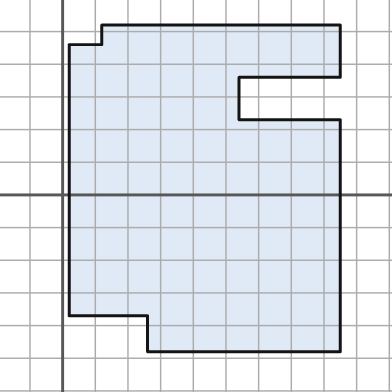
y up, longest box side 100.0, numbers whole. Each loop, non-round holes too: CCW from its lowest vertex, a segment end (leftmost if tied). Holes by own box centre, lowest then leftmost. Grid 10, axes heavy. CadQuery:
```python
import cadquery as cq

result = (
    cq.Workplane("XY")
    .moveTo(26.0, -48.0)
    .lineTo(85.0, -48.0)
    .lineTo(85.0, 23.0)
    .lineTo(54.0, 23.0)
    .lineTo(54.0, 36.0)
    .lineTo(85.0, 36.0)
    .lineTo(85.0, 52.0)
    .lineTo(12.0, 52.0)
    .lineTo(12.0, 46.0)
    .lineTo(2.0, 46.0)
    .lineTo(2.0, -37.0)
    .lineTo(26.0, -37.0)
    .close()
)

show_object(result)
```